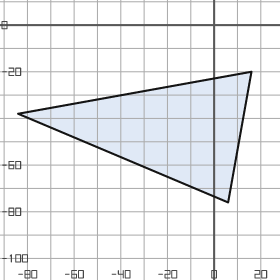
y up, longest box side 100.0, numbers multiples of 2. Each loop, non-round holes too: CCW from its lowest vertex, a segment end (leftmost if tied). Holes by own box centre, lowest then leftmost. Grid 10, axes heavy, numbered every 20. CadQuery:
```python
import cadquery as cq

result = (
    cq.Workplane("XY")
    .moveTo(6.0, -76.0)
    .lineTo(16.0, -20.0)
    .lineTo(-84.0, -38.0)
    .close()
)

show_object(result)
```